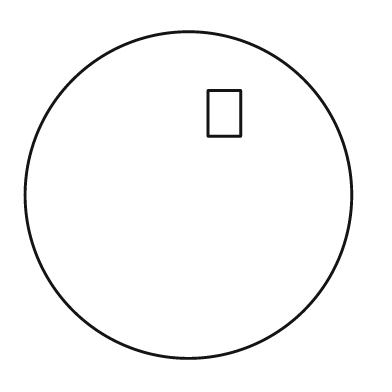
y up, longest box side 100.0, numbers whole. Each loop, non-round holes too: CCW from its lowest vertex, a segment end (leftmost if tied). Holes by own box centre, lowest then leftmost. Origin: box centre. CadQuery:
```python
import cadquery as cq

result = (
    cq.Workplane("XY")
    .moveTo(0.0, 0.0)
    .circle(50.0)
    .moveTo(6.0, 18.0)
    .lineTo(16.0, 18.0)
    .lineTo(16.0, 32.0)
    .lineTo(6.0, 32.0)
    .close()
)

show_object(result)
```